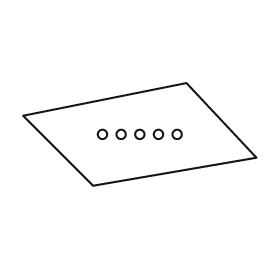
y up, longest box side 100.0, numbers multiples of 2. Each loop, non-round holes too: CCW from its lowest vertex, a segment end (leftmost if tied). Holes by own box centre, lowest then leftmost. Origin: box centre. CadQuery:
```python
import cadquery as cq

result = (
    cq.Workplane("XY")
    .moveTo(-20.0, -22.0)
    .lineTo(50.0, -10.0)
    .lineTo(20.0, 22.0)
    .lineTo(-50.0, 8.0)
    .close()
    .moveTo(-16.0, 0.0)
    .circle(2.0)
    .moveTo(-8.0, 0.0)
    .circle(2.0)
    .moveTo(0.0, 0.0)
    .circle(2.0)
    .moveTo(8.0, 0.0)
    .circle(2.0)
    .moveTo(16.0, 0.0)
    .circle(2.0)
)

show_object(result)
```